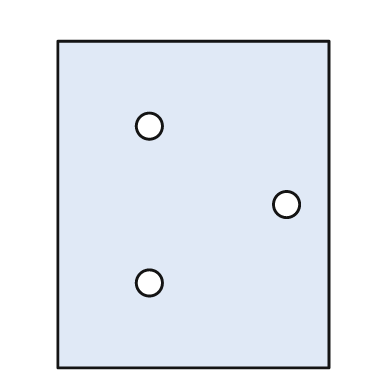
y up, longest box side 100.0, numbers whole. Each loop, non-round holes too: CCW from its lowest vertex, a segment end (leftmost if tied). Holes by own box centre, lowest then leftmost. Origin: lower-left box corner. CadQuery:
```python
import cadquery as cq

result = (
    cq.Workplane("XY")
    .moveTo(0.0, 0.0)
    .lineTo(83.0, 0.0)
    .lineTo(83.0, 100.0)
    .lineTo(0.0, 100.0)
    .close()
    .moveTo(28.0, 26.0)
    .circle(4.0)
    .moveTo(70.0, 50.0)
    .circle(4.0)
    .moveTo(28.0, 74.0)
    .circle(4.0)
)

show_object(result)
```